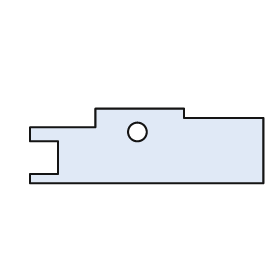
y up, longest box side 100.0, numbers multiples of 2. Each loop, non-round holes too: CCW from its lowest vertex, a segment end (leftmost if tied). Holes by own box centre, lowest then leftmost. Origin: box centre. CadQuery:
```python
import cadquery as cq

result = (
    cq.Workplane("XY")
    .moveTo(-50.0, -16.0)
    .lineTo(50.0, -16.0)
    .lineTo(50.0, 12.0)
    .lineTo(16.0, 12.0)
    .lineTo(16.0, 16.0)
    .lineTo(-22.0, 16.0)
    .lineTo(-22.0, 8.0)
    .lineTo(-50.0, 8.0)
    .lineTo(-50.0, 2.0)
    .lineTo(-38.0, 2.0)
    .lineTo(-38.0, -12.0)
    .lineTo(-50.0, -12.0)
    .close()
    .moveTo(-4.0, 6.0)
    .circle(4.0)
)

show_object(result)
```